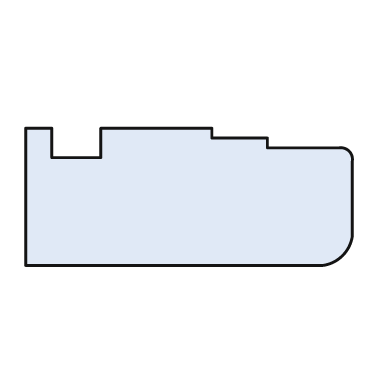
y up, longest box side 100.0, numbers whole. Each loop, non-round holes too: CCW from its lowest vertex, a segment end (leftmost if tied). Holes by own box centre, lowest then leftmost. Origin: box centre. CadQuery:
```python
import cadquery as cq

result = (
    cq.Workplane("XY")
    .moveTo(-50.0, -21.0)
    .lineTo(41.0, -21.0)
    .threePointArc((47.0, -18.0), (50.0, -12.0))
    .lineTo(50.0, 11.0)
    .threePointArc((49.0, 14.0), (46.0, 15.0))
    .lineTo(24.0, 15.0)
    .lineTo(24.0, 18.0)
    .lineTo(7.0, 18.0)
    .lineTo(7.0, 21.0)
    .lineTo(-27.0, 21.0)
    .lineTo(-27.0, 12.0)
    .lineTo(-42.0, 12.0)
    .lineTo(-42.0, 21.0)
    .lineTo(-50.0, 21.0)
    .close()
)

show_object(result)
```